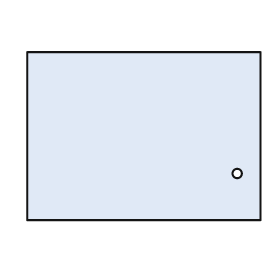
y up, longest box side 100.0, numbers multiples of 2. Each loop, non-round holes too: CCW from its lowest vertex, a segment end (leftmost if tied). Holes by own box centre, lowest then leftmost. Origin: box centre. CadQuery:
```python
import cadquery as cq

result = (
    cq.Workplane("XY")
    .moveTo(-50.0, -36.0)
    .lineTo(50.0, -36.0)
    .lineTo(50.0, 36.0)
    .lineTo(-50.0, 36.0)
    .close()
    .moveTo(40.0, -16.0)
    .circle(2.0)
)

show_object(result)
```